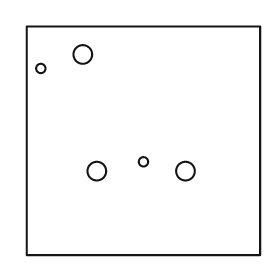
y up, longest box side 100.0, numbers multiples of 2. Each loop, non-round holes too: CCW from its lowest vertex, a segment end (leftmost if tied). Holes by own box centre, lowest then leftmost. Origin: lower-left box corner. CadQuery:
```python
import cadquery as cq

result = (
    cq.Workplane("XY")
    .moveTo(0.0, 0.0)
    .lineTo(100.0, 0.0)
    .lineTo(100.0, 98.0)
    .lineTo(0.0, 98.0)
    .close()
    .moveTo(30.0, 36.0)
    .circle(4.0)
    .moveTo(68.0, 36.0)
    .circle(4.0)
    .moveTo(50.0, 40.0)
    .circle(2.0)
    .moveTo(6.0, 80.0)
    .circle(2.0)
    .moveTo(24.0, 86.0)
    .circle(4.0)
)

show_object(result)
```